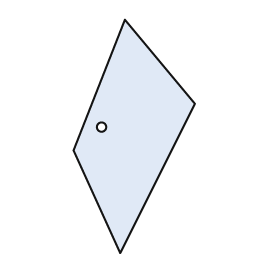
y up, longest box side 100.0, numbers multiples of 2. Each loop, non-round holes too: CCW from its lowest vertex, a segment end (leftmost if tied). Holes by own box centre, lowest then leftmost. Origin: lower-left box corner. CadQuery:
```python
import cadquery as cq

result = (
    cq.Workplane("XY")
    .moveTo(20.0, 0.0)
    .lineTo(52.0, 64.0)
    .lineTo(22.0, 100.0)
    .lineTo(0.0, 44.0)
    .close()
    .moveTo(12.0, 54.0)
    .circle(2.0)
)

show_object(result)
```